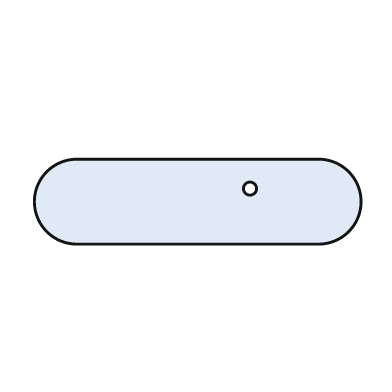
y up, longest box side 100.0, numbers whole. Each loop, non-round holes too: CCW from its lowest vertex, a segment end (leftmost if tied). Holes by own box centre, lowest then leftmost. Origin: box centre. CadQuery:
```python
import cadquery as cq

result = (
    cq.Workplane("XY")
    .moveTo(-37.0, -13.0)
    .lineTo(37.0, -13.0)
    .threePointArc((50.0, 0.0), (37.0, 13.0))
    .lineTo(-37.0, 13.0)
    .threePointArc((-50.0, 0.0), (-37.0, -13.0))
    .close()
    .moveTo(16.0, 4.0)
    .circle(2.0)
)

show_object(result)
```